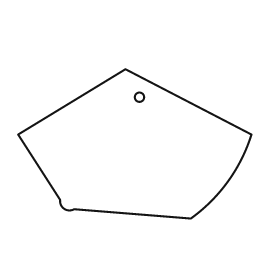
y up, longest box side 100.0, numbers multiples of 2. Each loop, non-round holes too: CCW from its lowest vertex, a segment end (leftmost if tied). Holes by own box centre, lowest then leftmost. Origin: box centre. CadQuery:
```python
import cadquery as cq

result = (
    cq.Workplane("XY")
    .moveTo(24.0, -32.0)
    .threePointArc((40.0, -16.0), (50.0, 4.0))
    .lineTo(-4.0, 32.0)
    .lineTo(-50.0, 4.0)
    .lineTo(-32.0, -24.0)
    .threePointArc((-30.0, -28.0), (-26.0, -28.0))
    .close()
    .moveTo(2.0, 20.0)
    .circle(2.0)
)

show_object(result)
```